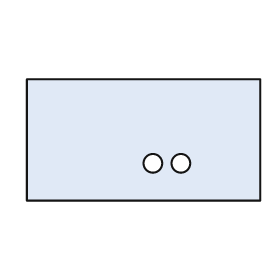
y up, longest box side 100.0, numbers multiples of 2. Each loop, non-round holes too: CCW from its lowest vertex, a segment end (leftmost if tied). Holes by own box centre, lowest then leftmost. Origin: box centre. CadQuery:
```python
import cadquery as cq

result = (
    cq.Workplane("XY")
    .moveTo(-50.0, -26.0)
    .lineTo(50.0, -26.0)
    .lineTo(50.0, 26.0)
    .lineTo(-50.0, 26.0)
    .close()
    .moveTo(4.0, -10.0)
    .circle(4.0)
    .moveTo(16.0, -10.0)
    .circle(4.0)
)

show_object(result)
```